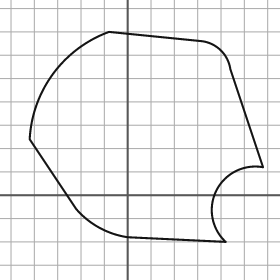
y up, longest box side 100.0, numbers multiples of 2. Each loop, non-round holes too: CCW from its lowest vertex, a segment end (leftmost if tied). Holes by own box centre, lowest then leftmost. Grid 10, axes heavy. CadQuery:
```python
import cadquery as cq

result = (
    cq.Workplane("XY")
    .moveTo(42.0, -20.0)
    .threePointArc((38.0, 2.0), (58.0, 12.0))
    .lineTo(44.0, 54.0)
    .threePointArc((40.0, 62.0), (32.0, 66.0))
    .lineTo(-8.0, 70.0)
    .threePointArc((-32.0, 52.0), (-42.0, 24.0))
    .lineTo(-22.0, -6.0)
    .threePointArc((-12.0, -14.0), (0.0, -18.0))
    .close()
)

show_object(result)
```